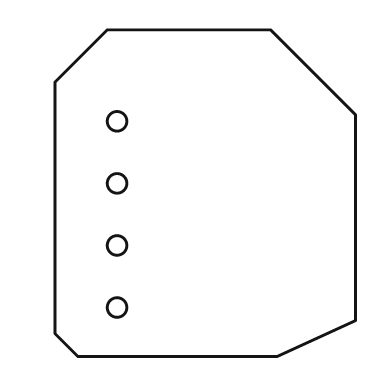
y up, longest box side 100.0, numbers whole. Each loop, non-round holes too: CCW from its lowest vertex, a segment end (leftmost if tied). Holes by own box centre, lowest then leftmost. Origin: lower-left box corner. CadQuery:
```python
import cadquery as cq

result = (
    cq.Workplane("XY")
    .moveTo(7.0, 0.0)
    .lineTo(68.0, 0.0)
    .lineTo(92.0, 11.0)
    .lineTo(92.0, 74.0)
    .lineTo(66.0, 100.0)
    .lineTo(16.0, 100.0)
    .lineTo(0.0, 84.0)
    .lineTo(0.0, 7.0)
    .close()
    .moveTo(19.0, 15.0)
    .circle(3.0)
    .moveTo(19.0, 34.0)
    .circle(3.0)
    .moveTo(19.0, 53.0)
    .circle(3.0)
    .moveTo(19.0, 72.0)
    .circle(3.0)
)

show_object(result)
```